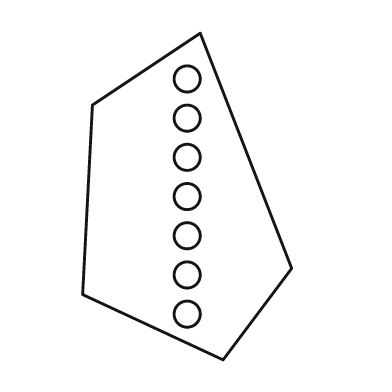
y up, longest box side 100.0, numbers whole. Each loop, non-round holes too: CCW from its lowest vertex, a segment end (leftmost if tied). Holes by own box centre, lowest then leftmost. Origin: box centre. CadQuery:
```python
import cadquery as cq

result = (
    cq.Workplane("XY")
    .moveTo(11.0, -50.0)
    .lineTo(32.0, -22.0)
    .lineTo(4.0, 50.0)
    .lineTo(-29.0, 28.0)
    .lineTo(-32.0, -30.0)
    .close()
    .moveTo(0.0, -36.0)
    .circle(4.0)
    .moveTo(0.0, -24.0)
    .circle(4.0)
    .moveTo(0.0, -12.0)
    .circle(4.0)
    .moveTo(0.0, 0.0)
    .circle(4.0)
    .moveTo(0.0, 12.0)
    .circle(4.0)
    .moveTo(0.0, 24.0)
    .circle(4.0)
    .moveTo(0.0, 36.0)
    .circle(4.0)
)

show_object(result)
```